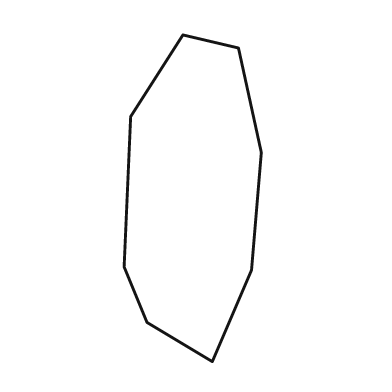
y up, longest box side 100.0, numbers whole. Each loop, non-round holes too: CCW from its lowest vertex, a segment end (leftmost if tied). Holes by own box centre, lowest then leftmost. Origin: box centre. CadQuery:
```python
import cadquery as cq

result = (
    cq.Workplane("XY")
    .moveTo(6.0, -50.0)
    .lineTo(18.0, -22.0)
    .lineTo(21.0, 14.0)
    .lineTo(14.0, 46.0)
    .lineTo(-3.0, 50.0)
    .lineTo(-19.0, 25.0)
    .lineTo(-21.0, -21.0)
    .lineTo(-14.0, -38.0)
    .close()
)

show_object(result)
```